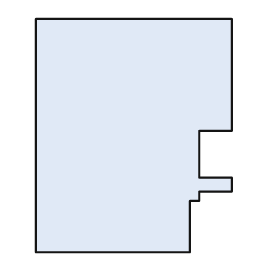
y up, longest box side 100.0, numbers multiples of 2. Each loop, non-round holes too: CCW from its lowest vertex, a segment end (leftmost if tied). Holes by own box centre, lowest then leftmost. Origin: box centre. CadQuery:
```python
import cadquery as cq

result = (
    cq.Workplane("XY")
    .moveTo(-42.0, -50.0)
    .lineTo(24.0, -50.0)
    .lineTo(24.0, -28.0)
    .lineTo(28.0, -28.0)
    .lineTo(28.0, -24.0)
    .lineTo(42.0, -24.0)
    .lineTo(42.0, -18.0)
    .lineTo(28.0, -18.0)
    .lineTo(28.0, 2.0)
    .lineTo(42.0, 2.0)
    .lineTo(42.0, 50.0)
    .lineTo(-42.0, 50.0)
    .close()
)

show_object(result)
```